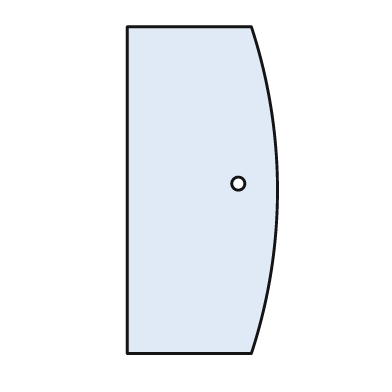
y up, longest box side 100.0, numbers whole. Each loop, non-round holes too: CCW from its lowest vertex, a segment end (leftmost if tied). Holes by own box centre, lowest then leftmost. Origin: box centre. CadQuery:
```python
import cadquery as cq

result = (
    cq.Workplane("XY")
    .moveTo(-23.0, -50.0)
    .lineTo(15.0, -50.0)
    .threePointArc((23.0, 0.0), (15.0, 50.0))
    .lineTo(-23.0, 50.0)
    .close()
    .moveTo(11.0, 2.0)
    .circle(2.0)
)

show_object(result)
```